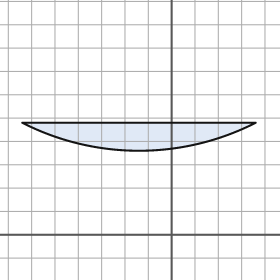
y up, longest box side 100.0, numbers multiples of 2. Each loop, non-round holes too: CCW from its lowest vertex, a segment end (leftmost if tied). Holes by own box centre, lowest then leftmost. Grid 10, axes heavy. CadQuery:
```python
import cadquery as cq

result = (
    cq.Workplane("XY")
    .moveTo(-64.0, 48.0)
    .threePointArc((-14.0, 36.0), (36.0, 48.0))
    .close()
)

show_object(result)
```